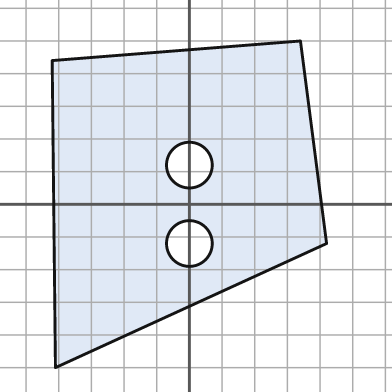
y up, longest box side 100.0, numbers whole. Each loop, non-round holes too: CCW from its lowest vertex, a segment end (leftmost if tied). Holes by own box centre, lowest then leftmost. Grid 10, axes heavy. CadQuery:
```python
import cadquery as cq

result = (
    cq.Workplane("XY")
    .moveTo(-41.0, -50.0)
    .lineTo(42.0, -12.0)
    .lineTo(34.0, 50.0)
    .lineTo(-42.0, 44.0)
    .close()
    .moveTo(0.0, -12.0)
    .circle(7.0)
    .moveTo(0.0, 12.0)
    .circle(7.0)
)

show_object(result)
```